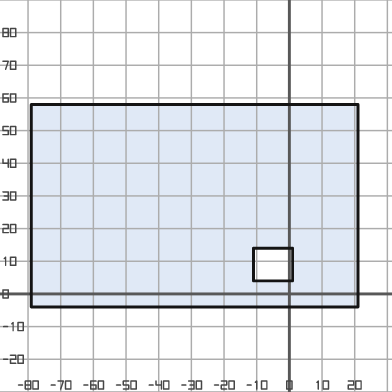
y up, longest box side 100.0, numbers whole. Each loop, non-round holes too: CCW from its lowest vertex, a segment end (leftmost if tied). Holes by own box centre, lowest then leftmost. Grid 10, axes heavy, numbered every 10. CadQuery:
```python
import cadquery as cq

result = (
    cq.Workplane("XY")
    .moveTo(-79.0, -4.0)
    .lineTo(21.0, -4.0)
    .lineTo(21.0, 58.0)
    .lineTo(-79.0, 58.0)
    .close()
    .moveTo(-11.0, 4.0)
    .lineTo(1.0, 4.0)
    .lineTo(1.0, 14.0)
    .lineTo(-11.0, 14.0)
    .close()
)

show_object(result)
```